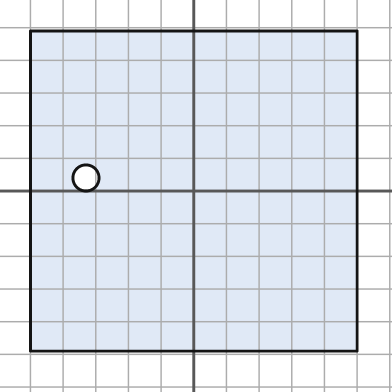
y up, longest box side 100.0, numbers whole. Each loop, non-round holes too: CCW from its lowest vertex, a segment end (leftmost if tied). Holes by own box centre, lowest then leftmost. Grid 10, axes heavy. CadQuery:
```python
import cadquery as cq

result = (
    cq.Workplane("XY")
    .moveTo(-50.0, -49.0)
    .lineTo(50.0, -49.0)
    .lineTo(50.0, 49.0)
    .lineTo(-50.0, 49.0)
    .close()
    .moveTo(-33.0, 4.0)
    .circle(4.0)
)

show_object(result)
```